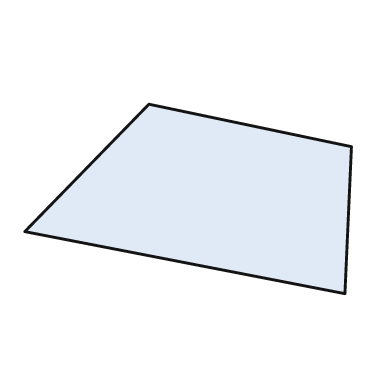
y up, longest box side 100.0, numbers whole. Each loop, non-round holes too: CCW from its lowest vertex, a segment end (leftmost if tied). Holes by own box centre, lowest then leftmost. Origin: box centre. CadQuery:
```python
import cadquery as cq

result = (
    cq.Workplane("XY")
    .moveTo(48.0, -29.0)
    .lineTo(50.0, 16.0)
    .lineTo(-12.0, 29.0)
    .lineTo(-50.0, -10.0)
    .close()
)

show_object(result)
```